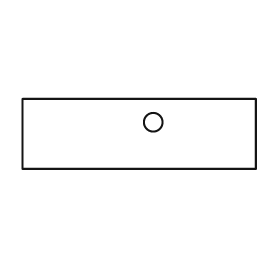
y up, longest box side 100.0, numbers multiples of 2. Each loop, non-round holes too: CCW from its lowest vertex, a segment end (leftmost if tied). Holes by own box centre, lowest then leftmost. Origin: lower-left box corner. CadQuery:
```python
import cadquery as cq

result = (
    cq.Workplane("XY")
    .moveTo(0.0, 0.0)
    .lineTo(100.0, 0.0)
    .lineTo(100.0, 30.0)
    .lineTo(0.0, 30.0)
    .close()
    .moveTo(56.0, 20.0)
    .circle(4.0)
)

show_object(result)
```